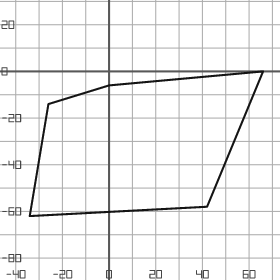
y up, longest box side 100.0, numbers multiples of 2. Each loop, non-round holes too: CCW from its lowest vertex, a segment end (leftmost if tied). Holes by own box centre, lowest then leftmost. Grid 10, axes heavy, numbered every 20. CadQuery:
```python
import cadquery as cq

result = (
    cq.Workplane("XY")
    .moveTo(-34.0, -62.0)
    .lineTo(42.0, -58.0)
    .lineTo(66.0, 0.0)
    .lineTo(0.0, -6.0)
    .lineTo(-26.0, -14.0)
    .close()
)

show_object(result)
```